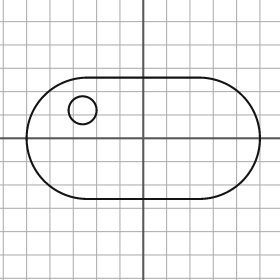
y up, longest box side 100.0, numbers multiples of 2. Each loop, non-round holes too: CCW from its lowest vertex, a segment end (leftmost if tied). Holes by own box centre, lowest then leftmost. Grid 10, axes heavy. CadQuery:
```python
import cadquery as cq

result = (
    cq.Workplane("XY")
    .moveTo(-24.0, -26.0)
    .lineTo(24.0, -26.0)
    .threePointArc((50.0, 0.0), (24.0, 26.0))
    .lineTo(-24.0, 26.0)
    .threePointArc((-50.0, 0.0), (-24.0, -26.0))
    .close()
    .moveTo(-26.0, 12.0)
    .circle(6.0)
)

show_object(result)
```